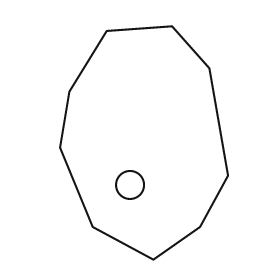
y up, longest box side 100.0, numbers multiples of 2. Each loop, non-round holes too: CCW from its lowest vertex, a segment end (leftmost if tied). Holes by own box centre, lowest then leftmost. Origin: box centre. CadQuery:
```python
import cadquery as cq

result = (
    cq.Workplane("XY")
    .moveTo(4.0, -50.0)
    .lineTo(24.0, -36.0)
    .lineTo(36.0, -14.0)
    .lineTo(28.0, 32.0)
    .lineTo(12.0, 50.0)
    .lineTo(-16.0, 48.0)
    .lineTo(-32.0, 22.0)
    .lineTo(-36.0, -2.0)
    .lineTo(-22.0, -36.0)
    .close()
    .moveTo(-6.0, -18.0)
    .circle(6.0)
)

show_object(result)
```